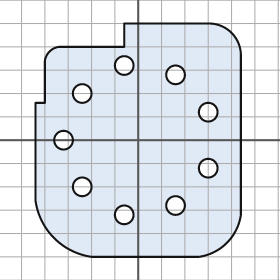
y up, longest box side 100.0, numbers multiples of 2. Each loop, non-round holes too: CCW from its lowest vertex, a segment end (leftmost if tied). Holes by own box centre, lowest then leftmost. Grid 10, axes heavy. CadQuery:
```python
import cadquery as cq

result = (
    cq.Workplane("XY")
    .moveTo(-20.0, -50.0)
    .lineTo(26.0, -50.0)
    .threePointArc((38.0, -44.0), (44.0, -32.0))
    .lineTo(44.0, 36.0)
    .threePointArc((40.0, 46.0), (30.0, 50.0))
    .lineTo(-6.0, 50.0)
    .lineTo(-6.0, 40.0)
    .lineTo(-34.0, 40.0)
    .threePointArc((-38.0, 38.0), (-40.0, 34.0))
    .lineTo(-40.0, 16.0)
    .lineTo(-44.0, 16.0)
    .lineTo(-44.0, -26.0)
    .threePointArc((-36.0, -42.0), (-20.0, -50.0))
    .close()
    .moveTo(-6.0, -32.0)
    .circle(4.0)
    .moveTo(16.0, -28.0)
    .circle(4.0)
    .moveTo(-24.0, -20.0)
    .circle(4.0)
    .moveTo(30.0, -12.0)
    .circle(4.0)
    .moveTo(-32.0, 0.0)
    .circle(4.0)
    .moveTo(30.0, 12.0)
    .circle(4.0)
    .moveTo(-24.0, 20.0)
    .circle(4.0)
    .moveTo(16.0, 28.0)
    .circle(4.0)
    .moveTo(-6.0, 32.0)
    .circle(4.0)
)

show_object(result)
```